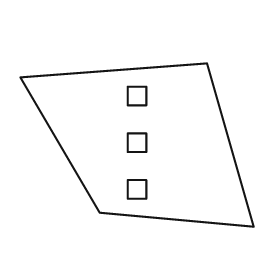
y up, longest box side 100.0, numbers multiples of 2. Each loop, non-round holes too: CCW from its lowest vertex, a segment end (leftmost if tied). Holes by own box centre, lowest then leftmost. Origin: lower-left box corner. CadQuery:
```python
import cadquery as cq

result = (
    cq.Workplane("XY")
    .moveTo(100.0, 0.0)
    .lineTo(80.0, 70.0)
    .lineTo(0.0, 64.0)
    .lineTo(34.0, 6.0)
    .close()
    .moveTo(46.0, 12.0)
    .lineTo(54.0, 12.0)
    .lineTo(54.0, 20.0)
    .lineTo(46.0, 20.0)
    .close()
    .moveTo(46.0, 32.0)
    .lineTo(54.0, 32.0)
    .lineTo(54.0, 40.0)
    .lineTo(46.0, 40.0)
    .close()
    .moveTo(46.0, 52.0)
    .lineTo(54.0, 52.0)
    .lineTo(54.0, 60.0)
    .lineTo(46.0, 60.0)
    .close()
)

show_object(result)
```